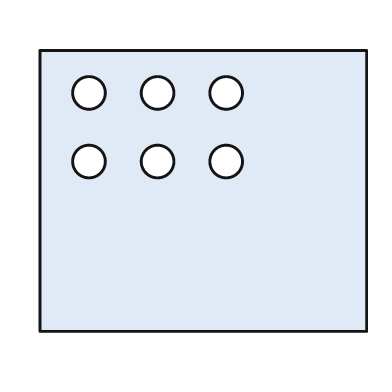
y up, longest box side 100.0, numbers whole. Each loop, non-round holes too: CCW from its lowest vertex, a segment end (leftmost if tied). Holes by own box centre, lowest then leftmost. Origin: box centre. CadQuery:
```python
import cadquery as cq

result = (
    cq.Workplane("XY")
    .moveTo(-50.0, -43.0)
    .lineTo(50.0, -43.0)
    .lineTo(50.0, 43.0)
    .lineTo(-50.0, 43.0)
    .close()
    .moveTo(-35.0, 9.0)
    .circle(5.0)
    .moveTo(-14.0, 9.0)
    .circle(5.0)
    .moveTo(7.0, 9.0)
    .circle(5.0)
    .moveTo(-35.0, 30.0)
    .circle(5.0)
    .moveTo(-14.0, 30.0)
    .circle(5.0)
    .moveTo(7.0, 30.0)
    .circle(5.0)
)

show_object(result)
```